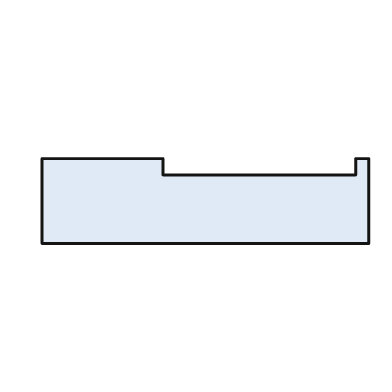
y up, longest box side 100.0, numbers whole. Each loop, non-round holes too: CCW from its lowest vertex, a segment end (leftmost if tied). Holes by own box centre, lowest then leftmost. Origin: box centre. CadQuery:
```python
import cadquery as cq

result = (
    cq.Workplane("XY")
    .moveTo(-50.0, -13.0)
    .lineTo(50.0, -13.0)
    .lineTo(50.0, 13.0)
    .lineTo(46.0, 13.0)
    .lineTo(46.0, 8.0)
    .lineTo(-13.0, 8.0)
    .lineTo(-13.0, 13.0)
    .lineTo(-50.0, 13.0)
    .close()
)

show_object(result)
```